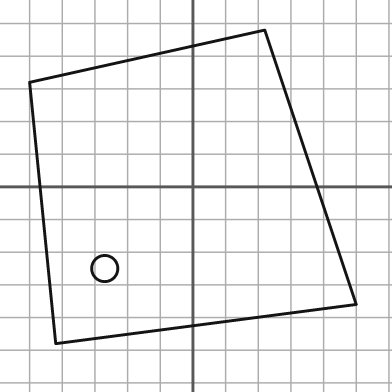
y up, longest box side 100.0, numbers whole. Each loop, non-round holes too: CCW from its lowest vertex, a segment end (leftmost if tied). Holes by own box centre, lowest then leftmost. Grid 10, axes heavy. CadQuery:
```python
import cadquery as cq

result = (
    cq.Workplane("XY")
    .moveTo(-42.0, -48.0)
    .lineTo(50.0, -36.0)
    .lineTo(22.0, 48.0)
    .lineTo(-50.0, 32.0)
    .close()
    .moveTo(-27.0, -25.0)
    .circle(4.0)
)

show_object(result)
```